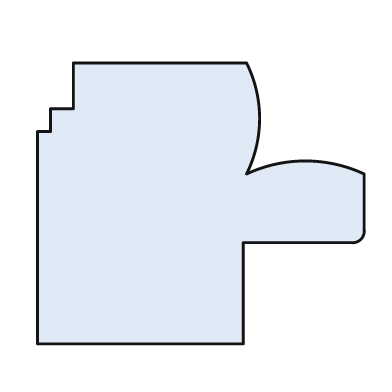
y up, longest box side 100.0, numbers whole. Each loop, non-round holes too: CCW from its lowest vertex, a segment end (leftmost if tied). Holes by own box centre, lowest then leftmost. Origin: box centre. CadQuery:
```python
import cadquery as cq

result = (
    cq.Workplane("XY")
    .moveTo(-50.0, -43.0)
    .lineTo(13.0, -43.0)
    .lineTo(13.0, -12.0)
    .lineTo(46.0, -12.0)
    .threePointArc((49.0, -11.0), (50.0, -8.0))
    .lineTo(50.0, 9.0)
    .threePointArc((32.0, 13.0), (14.0, 9.0))
    .threePointArc((18.0, 26.0), (14.0, 43.0))
    .lineTo(-39.0, 43.0)
    .lineTo(-39.0, 29.0)
    .lineTo(-46.0, 29.0)
    .lineTo(-46.0, 22.0)
    .lineTo(-50.0, 22.0)
    .close()
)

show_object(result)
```